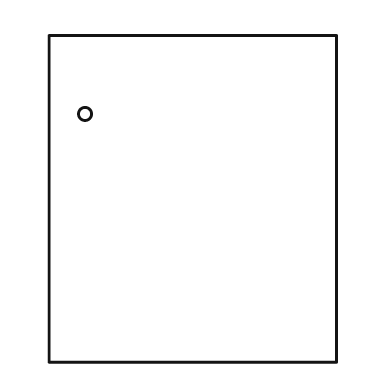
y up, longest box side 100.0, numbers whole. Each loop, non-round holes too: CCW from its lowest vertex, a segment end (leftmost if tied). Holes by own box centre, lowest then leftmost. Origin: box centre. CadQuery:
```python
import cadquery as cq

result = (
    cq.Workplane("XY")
    .moveTo(-44.0, -50.0)
    .lineTo(44.0, -50.0)
    .lineTo(44.0, 50.0)
    .lineTo(-44.0, 50.0)
    .close()
    .moveTo(-33.0, 26.0)
    .circle(2.0)
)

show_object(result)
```